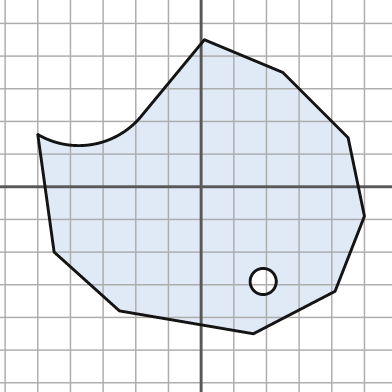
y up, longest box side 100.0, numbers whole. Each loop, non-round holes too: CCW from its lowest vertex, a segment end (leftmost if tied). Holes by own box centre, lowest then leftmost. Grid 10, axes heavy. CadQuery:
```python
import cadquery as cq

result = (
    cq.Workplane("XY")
    .moveTo(16.0, -45.0)
    .lineTo(41.0, -32.0)
    .lineTo(50.0, -9.0)
    .lineTo(45.0, 15.0)
    .lineTo(25.0, 35.0)
    .lineTo(1.0, 45.0)
    .lineTo(-18.0, 22.0)
    .threePointArc((-33.0, 13.0), (-50.0, 16.0))
    .lineTo(-45.0, -20.0)
    .lineTo(-25.0, -38.0)
    .close()
    .moveTo(19.0, -29.0)
    .circle(4.0)
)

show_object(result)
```